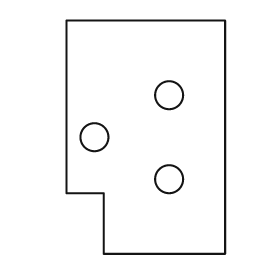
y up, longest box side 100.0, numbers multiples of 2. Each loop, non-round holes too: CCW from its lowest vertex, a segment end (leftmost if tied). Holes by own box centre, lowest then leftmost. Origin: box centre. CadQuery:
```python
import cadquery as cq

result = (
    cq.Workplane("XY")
    .moveTo(-18.0, -50.0)
    .lineTo(34.0, -50.0)
    .lineTo(34.0, 50.0)
    .lineTo(-34.0, 50.0)
    .lineTo(-34.0, -24.0)
    .lineTo(-18.0, -24.0)
    .close()
    .moveTo(10.0, -18.0)
    .circle(6.0)
    .moveTo(-22.0, 0.0)
    .circle(6.0)
    .moveTo(10.0, 18.0)
    .circle(6.0)
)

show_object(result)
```